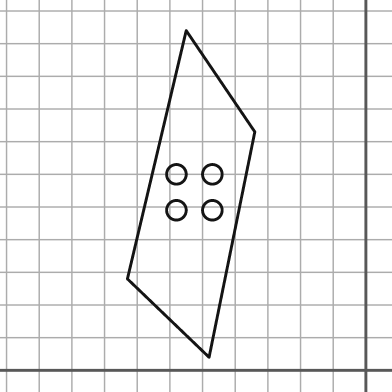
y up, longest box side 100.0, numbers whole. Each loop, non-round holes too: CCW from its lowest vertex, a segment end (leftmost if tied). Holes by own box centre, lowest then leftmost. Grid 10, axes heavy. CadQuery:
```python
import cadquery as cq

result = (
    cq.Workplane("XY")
    .moveTo(-48.0, 4.0)
    .lineTo(-34.0, 73.0)
    .lineTo(-55.0, 104.0)
    .lineTo(-73.0, 28.0)
    .close()
    .moveTo(-58.0, 49.0)
    .circle(3.0)
    .moveTo(-47.0, 49.0)
    .circle(3.0)
    .moveTo(-58.0, 60.0)
    .circle(3.0)
    .moveTo(-47.0, 60.0)
    .circle(3.0)
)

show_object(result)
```